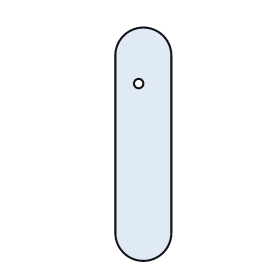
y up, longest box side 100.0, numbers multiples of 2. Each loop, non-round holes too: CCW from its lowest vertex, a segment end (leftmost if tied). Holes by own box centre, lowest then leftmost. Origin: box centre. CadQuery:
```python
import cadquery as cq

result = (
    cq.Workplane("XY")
    .moveTo(-12.0, -38.0)
    .threePointArc((0.0, -50.0), (12.0, -38.0))
    .lineTo(12.0, 38.0)
    .threePointArc((0.0, 50.0), (-12.0, 38.0))
    .close()
    .moveTo(-2.0, 26.0)
    .circle(2.0)
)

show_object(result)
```